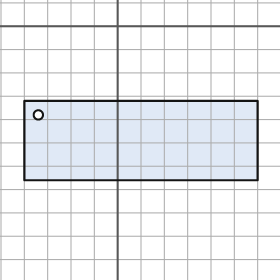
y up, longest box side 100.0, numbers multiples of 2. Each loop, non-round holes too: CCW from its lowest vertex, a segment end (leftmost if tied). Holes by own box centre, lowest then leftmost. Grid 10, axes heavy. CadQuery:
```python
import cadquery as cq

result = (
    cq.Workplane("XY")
    .moveTo(-40.0, -66.0)
    .lineTo(60.0, -66.0)
    .lineTo(60.0, -32.0)
    .lineTo(-40.0, -32.0)
    .close()
    .moveTo(-34.0, -38.0)
    .circle(2.0)
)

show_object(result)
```